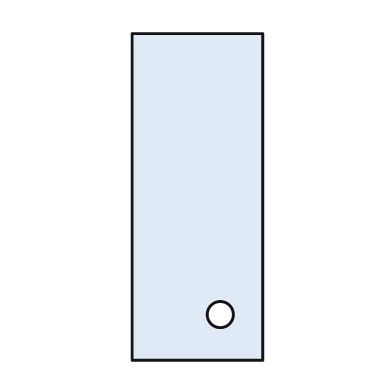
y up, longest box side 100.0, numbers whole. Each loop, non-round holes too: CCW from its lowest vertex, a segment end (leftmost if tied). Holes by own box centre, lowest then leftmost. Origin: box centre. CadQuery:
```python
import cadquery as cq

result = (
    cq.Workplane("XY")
    .moveTo(-20.0, -50.0)
    .lineTo(20.0, -50.0)
    .lineTo(20.0, 50.0)
    .lineTo(-20.0, 50.0)
    .close()
    .moveTo(7.0, -36.0)
    .circle(4.0)
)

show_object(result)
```